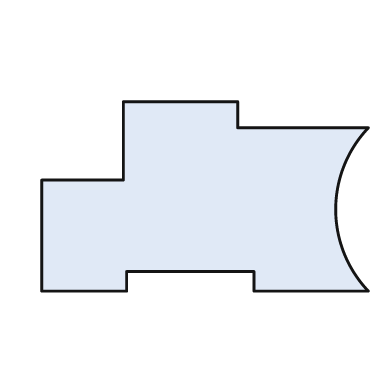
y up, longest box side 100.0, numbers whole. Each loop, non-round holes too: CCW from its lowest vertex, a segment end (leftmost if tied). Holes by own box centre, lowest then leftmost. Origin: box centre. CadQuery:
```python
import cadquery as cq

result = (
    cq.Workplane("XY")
    .moveTo(-50.0, -29.0)
    .lineTo(-24.0, -29.0)
    .lineTo(-24.0, -23.0)
    .lineTo(15.0, -23.0)
    .lineTo(15.0, -29.0)
    .lineTo(50.0, -29.0)
    .threePointArc((40.0, -4.0), (50.0, 21.0))
    .lineTo(10.0, 21.0)
    .lineTo(10.0, 29.0)
    .lineTo(-25.0, 29.0)
    .lineTo(-25.0, 5.0)
    .lineTo(-50.0, 5.0)
    .close()
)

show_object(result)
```